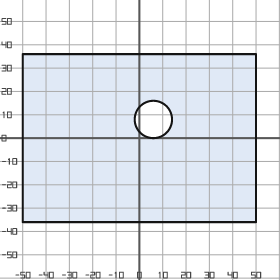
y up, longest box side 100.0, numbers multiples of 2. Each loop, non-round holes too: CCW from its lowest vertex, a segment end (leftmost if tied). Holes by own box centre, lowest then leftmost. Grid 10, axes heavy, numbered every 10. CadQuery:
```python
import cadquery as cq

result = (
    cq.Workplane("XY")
    .moveTo(-50.0, -36.0)
    .lineTo(50.0, -36.0)
    .lineTo(50.0, 36.0)
    .lineTo(-50.0, 36.0)
    .close()
    .moveTo(6.0, 8.0)
    .circle(8.0)
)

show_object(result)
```